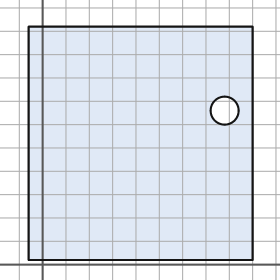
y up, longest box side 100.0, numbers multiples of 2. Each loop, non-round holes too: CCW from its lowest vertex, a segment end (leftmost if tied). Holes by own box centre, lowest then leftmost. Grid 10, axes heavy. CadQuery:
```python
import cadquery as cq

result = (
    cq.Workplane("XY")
    .moveTo(-6.0, 2.0)
    .lineTo(90.0, 2.0)
    .lineTo(90.0, 102.0)
    .lineTo(-6.0, 102.0)
    .close()
    .moveTo(78.0, 66.0)
    .circle(6.0)
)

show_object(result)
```